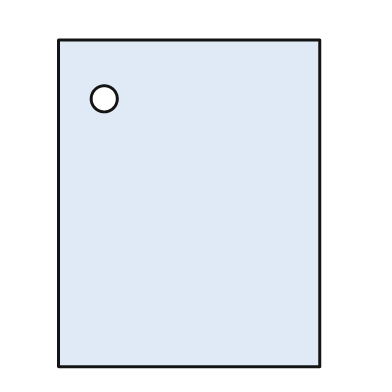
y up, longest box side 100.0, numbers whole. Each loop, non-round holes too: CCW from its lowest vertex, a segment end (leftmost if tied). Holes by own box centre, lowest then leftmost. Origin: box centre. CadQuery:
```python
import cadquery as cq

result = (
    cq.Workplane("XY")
    .moveTo(-40.0, -50.0)
    .lineTo(40.0, -50.0)
    .lineTo(40.0, 50.0)
    .lineTo(-40.0, 50.0)
    .close()
    .moveTo(-26.0, 32.0)
    .circle(4.0)
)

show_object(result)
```